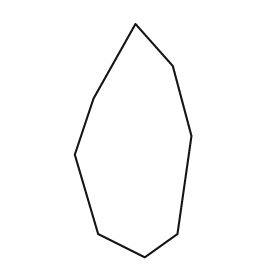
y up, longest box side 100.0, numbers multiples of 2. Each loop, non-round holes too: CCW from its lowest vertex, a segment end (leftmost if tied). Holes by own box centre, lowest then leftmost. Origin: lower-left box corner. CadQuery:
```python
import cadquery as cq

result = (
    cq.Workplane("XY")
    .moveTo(30.0, 0.0)
    .lineTo(44.0, 10.0)
    .lineTo(50.0, 52.0)
    .lineTo(42.0, 82.0)
    .lineTo(26.0, 100.0)
    .lineTo(8.0, 68.0)
    .lineTo(0.0, 44.0)
    .lineTo(10.0, 10.0)
    .close()
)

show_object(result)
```